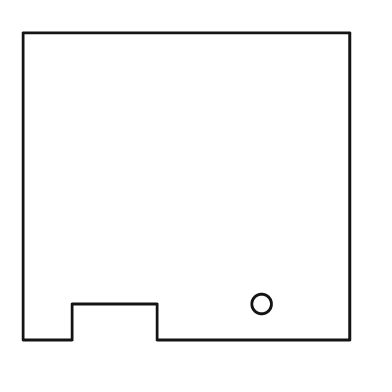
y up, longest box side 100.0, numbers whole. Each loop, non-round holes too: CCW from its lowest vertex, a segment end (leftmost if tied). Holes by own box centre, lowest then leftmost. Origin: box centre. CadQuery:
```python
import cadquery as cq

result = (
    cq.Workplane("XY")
    .moveTo(-50.0, -47.0)
    .lineTo(-35.0, -47.0)
    .lineTo(-35.0, -36.0)
    .lineTo(-9.0, -36.0)
    .lineTo(-9.0, -47.0)
    .lineTo(50.0, -47.0)
    .lineTo(50.0, 47.0)
    .lineTo(-50.0, 47.0)
    .close()
    .moveTo(23.0, -36.0)
    .circle(3.0)
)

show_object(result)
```